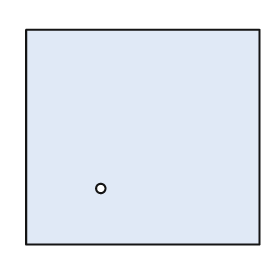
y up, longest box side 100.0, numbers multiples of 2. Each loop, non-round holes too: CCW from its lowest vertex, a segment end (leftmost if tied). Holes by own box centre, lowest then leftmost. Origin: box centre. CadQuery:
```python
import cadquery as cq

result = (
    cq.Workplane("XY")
    .moveTo(-50.0, -46.0)
    .lineTo(50.0, -46.0)
    .lineTo(50.0, 46.0)
    .lineTo(-50.0, 46.0)
    .close()
    .moveTo(-18.0, -22.0)
    .circle(2.0)
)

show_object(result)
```